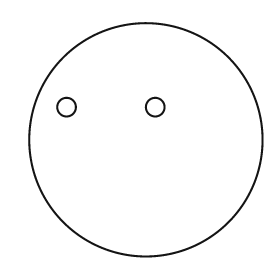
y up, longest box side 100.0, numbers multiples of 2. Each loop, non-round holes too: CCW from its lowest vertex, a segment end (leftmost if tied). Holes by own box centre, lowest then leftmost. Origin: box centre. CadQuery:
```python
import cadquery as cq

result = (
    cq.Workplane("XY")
    .moveTo(0.0, 0.0)
    .circle(50.0)
    .moveTo(-34.0, 14.0)
    .circle(4.0)
    .moveTo(4.0, 14.0)
    .circle(4.0)
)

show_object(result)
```